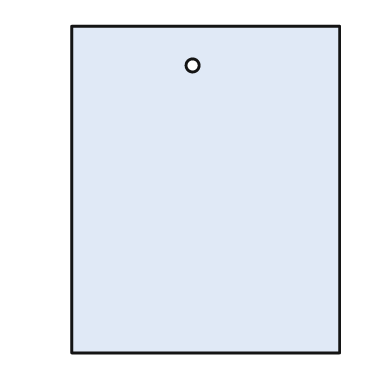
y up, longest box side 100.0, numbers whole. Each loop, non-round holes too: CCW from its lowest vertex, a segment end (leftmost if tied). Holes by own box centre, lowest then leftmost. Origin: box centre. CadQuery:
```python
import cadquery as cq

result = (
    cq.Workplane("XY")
    .moveTo(-41.0, -50.0)
    .lineTo(41.0, -50.0)
    .lineTo(41.0, 50.0)
    .lineTo(-41.0, 50.0)
    .close()
    .moveTo(-4.0, 38.0)
    .circle(2.0)
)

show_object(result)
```